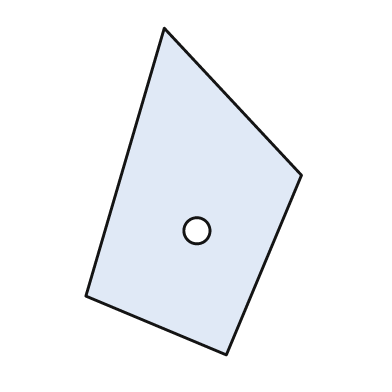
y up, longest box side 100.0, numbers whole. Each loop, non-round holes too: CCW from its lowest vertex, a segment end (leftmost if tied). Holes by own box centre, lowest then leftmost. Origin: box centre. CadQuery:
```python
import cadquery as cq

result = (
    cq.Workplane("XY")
    .moveTo(10.0, -50.0)
    .lineTo(33.0, 5.0)
    .lineTo(-9.0, 50.0)
    .lineTo(-33.0, -32.0)
    .close()
    .moveTo(1.0, -12.0)
    .circle(4.0)
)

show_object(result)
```